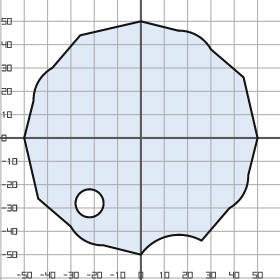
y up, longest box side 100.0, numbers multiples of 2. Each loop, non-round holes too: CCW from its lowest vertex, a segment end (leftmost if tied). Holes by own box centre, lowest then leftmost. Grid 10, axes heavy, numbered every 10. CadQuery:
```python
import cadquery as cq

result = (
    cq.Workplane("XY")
    .moveTo(0.0, -50.0)
    .threePointArc((12.0, -42.0), (26.0, -44.0))
    .lineTo(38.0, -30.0)
    .threePointArc((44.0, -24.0), (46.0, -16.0))
    .lineTo(50.0, 0.0)
    .lineTo(44.0, 26.0)
    .lineTo(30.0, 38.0)
    .threePointArc((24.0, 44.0), (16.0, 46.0))
    .lineTo(0.0, 50.0)
    .lineTo(-26.0, 44.0)
    .lineTo(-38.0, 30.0)
    .threePointArc((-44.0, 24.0), (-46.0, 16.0))
    .lineTo(-50.0, 0.0)
    .lineTo(-44.0, -26.0)
    .lineTo(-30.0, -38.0)
    .threePointArc((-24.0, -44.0), (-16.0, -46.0))
    .close()
    .moveTo(-22.0, -28.0)
    .circle(6.0)
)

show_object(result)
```